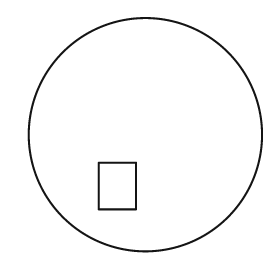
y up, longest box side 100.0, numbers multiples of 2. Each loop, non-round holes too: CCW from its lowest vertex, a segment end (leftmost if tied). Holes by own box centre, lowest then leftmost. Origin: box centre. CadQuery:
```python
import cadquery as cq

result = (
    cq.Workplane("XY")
    .moveTo(0.0, 0.0)
    .circle(50.0)
    .moveTo(-20.0, -32.0)
    .lineTo(-4.0, -32.0)
    .lineTo(-4.0, -12.0)
    .lineTo(-20.0, -12.0)
    .close()
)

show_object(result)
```